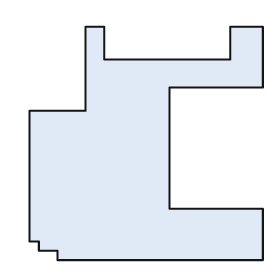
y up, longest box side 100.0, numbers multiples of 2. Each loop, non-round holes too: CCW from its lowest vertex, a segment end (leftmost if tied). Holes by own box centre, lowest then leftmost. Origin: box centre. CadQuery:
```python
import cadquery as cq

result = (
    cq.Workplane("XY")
    .moveTo(-38.0, -50.0)
    .lineTo(50.0, -50.0)
    .lineTo(50.0, -28.0)
    .lineTo(10.0, -28.0)
    .lineTo(10.0, 24.0)
    .lineTo(50.0, 24.0)
    .lineTo(50.0, 50.0)
    .lineTo(36.0, 50.0)
    .lineTo(36.0, 36.0)
    .lineTo(-18.0, 36.0)
    .lineTo(-18.0, 50.0)
    .lineTo(-26.0, 50.0)
    .lineTo(-26.0, 14.0)
    .lineTo(-50.0, 14.0)
    .lineTo(-50.0, -42.0)
    .lineTo(-46.0, -42.0)
    .lineTo(-46.0, -46.0)
    .lineTo(-38.0, -46.0)
    .close()
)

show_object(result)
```